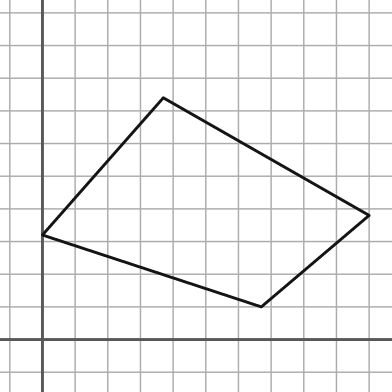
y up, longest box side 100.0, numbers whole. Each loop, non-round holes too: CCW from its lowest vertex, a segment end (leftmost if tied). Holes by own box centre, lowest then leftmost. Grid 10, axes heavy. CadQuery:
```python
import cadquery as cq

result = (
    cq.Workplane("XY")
    .moveTo(67.0, 10.0)
    .lineTo(100.0, 38.0)
    .lineTo(37.0, 74.0)
    .lineTo(0.0, 32.0)
    .close()
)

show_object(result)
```